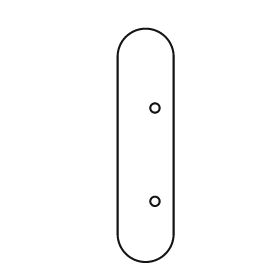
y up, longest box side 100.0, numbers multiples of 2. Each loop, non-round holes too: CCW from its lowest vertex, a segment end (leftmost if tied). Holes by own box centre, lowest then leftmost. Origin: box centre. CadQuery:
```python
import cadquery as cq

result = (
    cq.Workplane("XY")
    .moveTo(-12.0, -38.0)
    .threePointArc((0.0, -50.0), (12.0, -38.0))
    .lineTo(12.0, 38.0)
    .threePointArc((0.0, 50.0), (-12.0, 38.0))
    .close()
    .moveTo(4.0, -24.0)
    .circle(2.0)
    .moveTo(4.0, 16.0)
    .circle(2.0)
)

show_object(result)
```